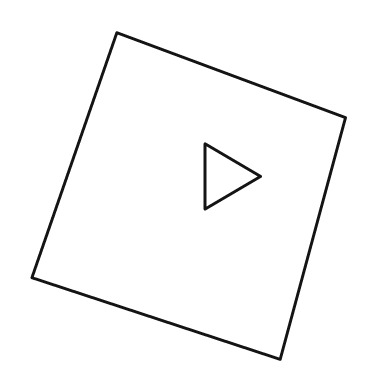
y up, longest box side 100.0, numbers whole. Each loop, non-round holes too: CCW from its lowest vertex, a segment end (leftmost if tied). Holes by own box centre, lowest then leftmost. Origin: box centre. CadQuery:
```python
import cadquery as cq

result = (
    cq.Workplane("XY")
    .moveTo(28.0, -50.0)
    .lineTo(48.0, 24.0)
    .lineTo(-22.0, 50.0)
    .lineTo(-48.0, -25.0)
    .close()
    .moveTo(5.0, -4.0)
    .lineTo(22.0, 6.0)
    .lineTo(5.0, 16.0)
    .close()
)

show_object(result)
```